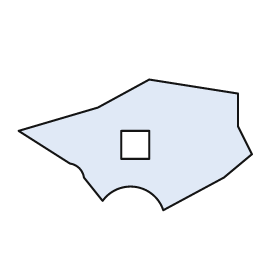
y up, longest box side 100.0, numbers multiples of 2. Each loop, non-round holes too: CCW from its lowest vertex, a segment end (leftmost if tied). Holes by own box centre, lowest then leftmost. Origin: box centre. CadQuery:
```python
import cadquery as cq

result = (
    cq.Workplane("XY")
    .moveTo(12.0, -28.0)
    .lineTo(38.0, -14.0)
    .lineTo(50.0, -4.0)
    .lineTo(44.0, 8.0)
    .lineTo(44.0, 22.0)
    .lineTo(6.0, 28.0)
    .lineTo(-16.0, 16.0)
    .lineTo(-50.0, 6.0)
    .lineTo(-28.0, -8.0)
    .threePointArc((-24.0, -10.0), (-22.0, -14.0))
    .lineTo(-14.0, -24.0)
    .threePointArc((0.0, -18.0), (12.0, -28.0))
    .close()
    .moveTo(-6.0, -6.0)
    .lineTo(6.0, -6.0)
    .lineTo(6.0, 6.0)
    .lineTo(-6.0, 6.0)
    .close()
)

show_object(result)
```